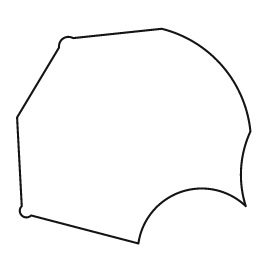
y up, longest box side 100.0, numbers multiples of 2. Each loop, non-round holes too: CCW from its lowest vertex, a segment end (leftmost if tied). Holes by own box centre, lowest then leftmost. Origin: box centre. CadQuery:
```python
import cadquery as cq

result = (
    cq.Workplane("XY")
    .moveTo(2.0, -46.0)
    .threePointArc((20.0, -24.0), (48.0, -30.0))
    .threePointArc((46.0, -14.0), (50.0, 2.0))
    .threePointArc((38.0, 30.0), (12.0, 46.0))
    .lineTo(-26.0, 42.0)
    .threePointArc((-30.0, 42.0), (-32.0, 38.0))
    .lineTo(-50.0, 8.0)
    .lineTo(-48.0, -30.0)
    .threePointArc((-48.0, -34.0), (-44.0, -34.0))
    .close()
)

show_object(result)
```